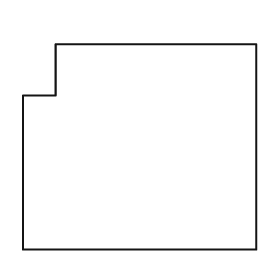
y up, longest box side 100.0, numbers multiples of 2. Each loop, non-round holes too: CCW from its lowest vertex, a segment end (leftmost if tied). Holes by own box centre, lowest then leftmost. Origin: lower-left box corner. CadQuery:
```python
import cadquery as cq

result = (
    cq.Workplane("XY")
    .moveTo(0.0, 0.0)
    .lineTo(100.0, 0.0)
    .lineTo(100.0, 88.0)
    .lineTo(14.0, 88.0)
    .lineTo(14.0, 66.0)
    .lineTo(0.0, 66.0)
    .close()
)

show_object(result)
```